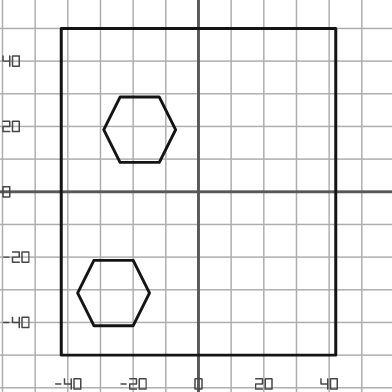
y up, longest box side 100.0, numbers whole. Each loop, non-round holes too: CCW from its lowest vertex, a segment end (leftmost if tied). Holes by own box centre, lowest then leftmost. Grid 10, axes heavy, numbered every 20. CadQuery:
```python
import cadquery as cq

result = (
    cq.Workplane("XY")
    .moveTo(-42.0, -50.0)
    .lineTo(42.0, -50.0)
    .lineTo(42.0, 50.0)
    .lineTo(-42.0, 50.0)
    .close()
    .moveTo(-32.0, -41.0)
    .lineTo(-20.0, -41.0)
    .lineTo(-15.0, -31.0)
    .lineTo(-20.0, -21.0)
    .lineTo(-32.0, -21.0)
    .lineTo(-37.0, -31.0)
    .close()
    .moveTo(-24.0, 9.0)
    .lineTo(-12.0, 9.0)
    .lineTo(-7.0, 19.0)
    .lineTo(-12.0, 29.0)
    .lineTo(-24.0, 29.0)
    .lineTo(-29.0, 19.0)
    .close()
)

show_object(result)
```